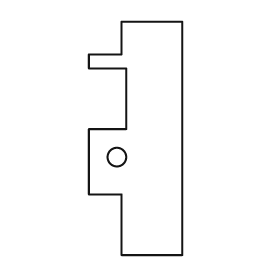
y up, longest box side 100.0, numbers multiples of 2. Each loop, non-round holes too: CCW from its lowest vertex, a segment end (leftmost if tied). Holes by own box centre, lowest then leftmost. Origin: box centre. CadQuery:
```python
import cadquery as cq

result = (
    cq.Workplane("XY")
    .moveTo(-6.0, -50.0)
    .lineTo(20.0, -50.0)
    .lineTo(20.0, 50.0)
    .lineTo(-6.0, 50.0)
    .lineTo(-6.0, 36.0)
    .lineTo(-20.0, 36.0)
    .lineTo(-20.0, 30.0)
    .lineTo(-4.0, 30.0)
    .lineTo(-4.0, 4.0)
    .lineTo(-20.0, 4.0)
    .lineTo(-20.0, -24.0)
    .lineTo(-6.0, -24.0)
    .close()
    .moveTo(-8.0, -8.0)
    .circle(4.0)
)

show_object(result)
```